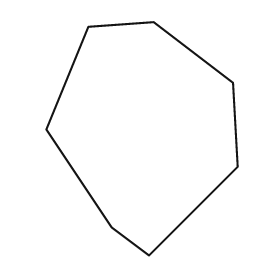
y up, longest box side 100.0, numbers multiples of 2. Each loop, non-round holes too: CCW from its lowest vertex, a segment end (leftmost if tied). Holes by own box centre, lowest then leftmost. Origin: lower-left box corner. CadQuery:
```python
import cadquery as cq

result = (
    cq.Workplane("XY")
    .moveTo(44.0, 0.0)
    .lineTo(82.0, 38.0)
    .lineTo(80.0, 74.0)
    .lineTo(46.0, 100.0)
    .lineTo(18.0, 98.0)
    .lineTo(0.0, 54.0)
    .lineTo(28.0, 12.0)
    .close()
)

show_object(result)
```